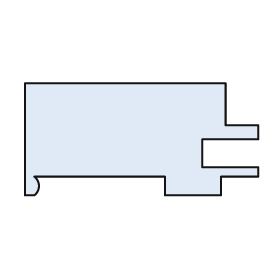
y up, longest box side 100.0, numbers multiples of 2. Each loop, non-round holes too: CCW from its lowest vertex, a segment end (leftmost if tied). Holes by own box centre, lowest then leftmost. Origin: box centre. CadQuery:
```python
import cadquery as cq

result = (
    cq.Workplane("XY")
    .moveTo(-50.0, -24.0)
    .lineTo(-46.0, -24.0)
    .threePointArc((-44.0, -20.0), (-46.0, -16.0))
    .lineTo(10.0, -16.0)
    .lineTo(10.0, -24.0)
    .lineTo(34.0, -24.0)
    .lineTo(34.0, -16.0)
    .lineTo(50.0, -16.0)
    .lineTo(50.0, -12.0)
    .lineTo(26.0, -12.0)
    .lineTo(26.0, 0.0)
    .lineTo(50.0, 0.0)
    .lineTo(50.0, 6.0)
    .lineTo(36.0, 6.0)
    .lineTo(36.0, 24.0)
    .lineTo(-50.0, 24.0)
    .close()
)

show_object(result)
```